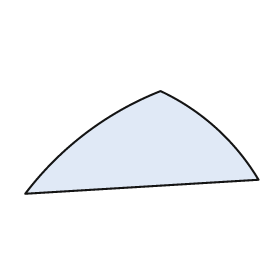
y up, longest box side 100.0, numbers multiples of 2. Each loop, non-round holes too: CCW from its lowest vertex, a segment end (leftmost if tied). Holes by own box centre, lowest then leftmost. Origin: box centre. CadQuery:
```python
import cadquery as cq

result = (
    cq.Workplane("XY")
    .moveTo(-50.0, -22.0)
    .lineTo(50.0, -16.0)
    .threePointArc((32.0, 6.0), (8.0, 22.0))
    .threePointArc((-24.0, 4.0), (-50.0, -22.0))
    .close()
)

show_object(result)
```